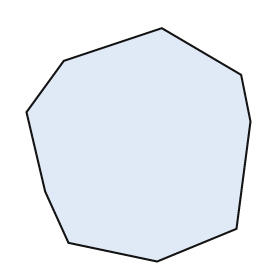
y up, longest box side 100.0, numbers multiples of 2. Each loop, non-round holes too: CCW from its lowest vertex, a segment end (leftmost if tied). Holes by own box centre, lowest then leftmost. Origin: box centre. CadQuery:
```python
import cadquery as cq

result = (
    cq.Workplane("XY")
    .moveTo(8.0, -50.0)
    .lineTo(42.0, -36.0)
    .lineTo(48.0, 10.0)
    .lineTo(44.0, 30.0)
    .lineTo(10.0, 50.0)
    .lineTo(-32.0, 36.0)
    .lineTo(-48.0, 14.0)
    .lineTo(-40.0, -20.0)
    .lineTo(-30.0, -42.0)
    .close()
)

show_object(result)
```